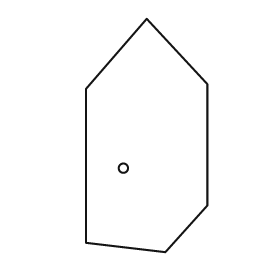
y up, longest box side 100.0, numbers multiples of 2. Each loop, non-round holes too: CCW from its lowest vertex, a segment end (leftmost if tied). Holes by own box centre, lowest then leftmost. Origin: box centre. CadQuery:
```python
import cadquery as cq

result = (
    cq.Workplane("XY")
    .moveTo(8.0, -50.0)
    .lineTo(26.0, -30.0)
    .lineTo(26.0, 22.0)
    .lineTo(0.0, 50.0)
    .lineTo(-26.0, 20.0)
    .lineTo(-26.0, -46.0)
    .close()
    .moveTo(-10.0, -14.0)
    .circle(2.0)
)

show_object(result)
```